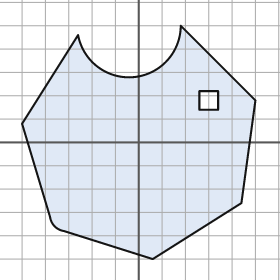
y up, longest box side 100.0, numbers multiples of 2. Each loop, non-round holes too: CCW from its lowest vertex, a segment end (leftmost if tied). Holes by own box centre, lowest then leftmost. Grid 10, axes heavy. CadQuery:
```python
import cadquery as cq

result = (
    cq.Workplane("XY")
    .moveTo(6.0, -50.0)
    .lineTo(44.0, -26.0)
    .lineTo(50.0, 18.0)
    .lineTo(18.0, 50.0)
    .threePointArc((-2.0, 28.0), (-26.0, 46.0))
    .lineTo(-50.0, 8.0)
    .lineTo(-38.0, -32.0)
    .threePointArc((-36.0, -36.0), (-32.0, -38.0))
    .close()
    .moveTo(26.0, 14.0)
    .lineTo(34.0, 14.0)
    .lineTo(34.0, 22.0)
    .lineTo(26.0, 22.0)
    .close()
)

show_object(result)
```